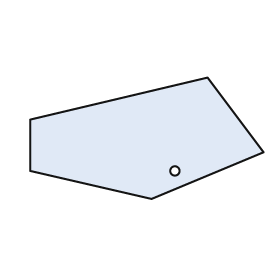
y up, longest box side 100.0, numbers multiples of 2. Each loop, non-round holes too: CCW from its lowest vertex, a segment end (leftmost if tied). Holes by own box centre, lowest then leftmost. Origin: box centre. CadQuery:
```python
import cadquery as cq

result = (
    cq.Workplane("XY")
    .moveTo(2.0, -26.0)
    .lineTo(50.0, -6.0)
    .lineTo(26.0, 26.0)
    .lineTo(-50.0, 8.0)
    .lineTo(-50.0, -14.0)
    .close()
    .moveTo(12.0, -14.0)
    .circle(2.0)
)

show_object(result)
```